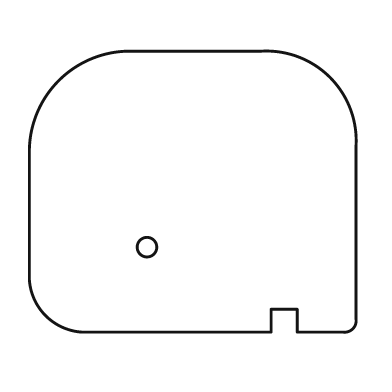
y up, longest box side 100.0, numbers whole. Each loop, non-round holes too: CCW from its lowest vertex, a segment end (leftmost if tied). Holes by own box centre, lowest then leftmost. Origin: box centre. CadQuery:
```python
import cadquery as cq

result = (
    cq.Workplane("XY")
    .moveTo(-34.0, -43.0)
    .lineTo(24.0, -43.0)
    .lineTo(24.0, -36.0)
    .lineTo(32.0, -36.0)
    .lineTo(32.0, -43.0)
    .lineTo(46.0, -43.0)
    .threePointArc((49.0, -42.0), (50.0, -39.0))
    .lineTo(50.0, 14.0)
    .threePointArc((42.0, 35.0), (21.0, 43.0))
    .lineTo(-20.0, 43.0)
    .threePointArc((-41.0, 34.0), (-50.0, 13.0))
    .lineTo(-50.0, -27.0)
    .threePointArc((-45.0, -38.0), (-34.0, -43.0))
    .close()
    .moveTo(-14.0, -17.0)
    .circle(3.0)
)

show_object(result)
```